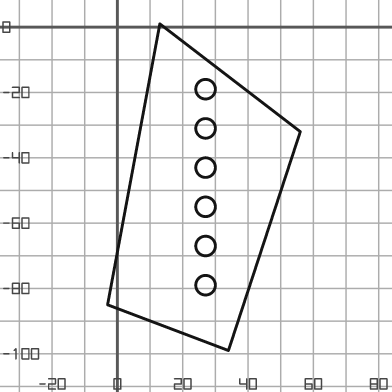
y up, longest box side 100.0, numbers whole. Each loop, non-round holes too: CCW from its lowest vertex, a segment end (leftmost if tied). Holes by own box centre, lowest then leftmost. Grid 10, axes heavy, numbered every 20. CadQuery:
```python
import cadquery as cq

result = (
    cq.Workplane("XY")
    .moveTo(34.0, -99.0)
    .lineTo(56.0, -32.0)
    .lineTo(13.0, 1.0)
    .lineTo(-3.0, -85.0)
    .close()
    .moveTo(27.0, -79.0)
    .circle(3.0)
    .moveTo(27.0, -67.0)
    .circle(3.0)
    .moveTo(27.0, -55.0)
    .circle(3.0)
    .moveTo(27.0, -43.0)
    .circle(3.0)
    .moveTo(27.0, -31.0)
    .circle(3.0)
    .moveTo(27.0, -19.0)
    .circle(3.0)
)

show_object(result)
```